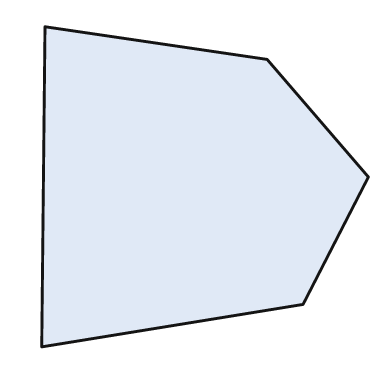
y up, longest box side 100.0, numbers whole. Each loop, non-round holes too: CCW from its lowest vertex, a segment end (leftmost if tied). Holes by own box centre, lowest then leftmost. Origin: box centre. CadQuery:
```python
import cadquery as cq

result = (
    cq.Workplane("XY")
    .moveTo(-50.0, -49.0)
    .lineTo(30.0, -36.0)
    .lineTo(50.0, 3.0)
    .lineTo(19.0, 39.0)
    .lineTo(-49.0, 49.0)
    .close()
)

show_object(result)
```